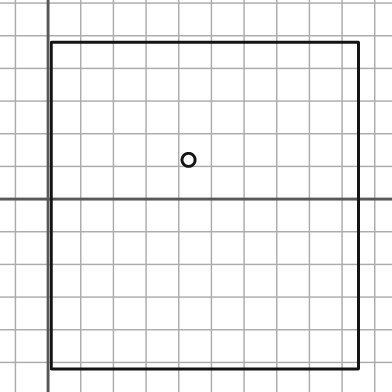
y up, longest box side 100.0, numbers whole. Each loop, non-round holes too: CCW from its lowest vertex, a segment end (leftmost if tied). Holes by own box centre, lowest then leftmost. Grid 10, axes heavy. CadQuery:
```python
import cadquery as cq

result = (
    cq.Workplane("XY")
    .moveTo(1.0, -52.0)
    .lineTo(95.0, -52.0)
    .lineTo(95.0, 48.0)
    .lineTo(1.0, 48.0)
    .close()
    .moveTo(43.0, 12.0)
    .circle(2.0)
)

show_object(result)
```